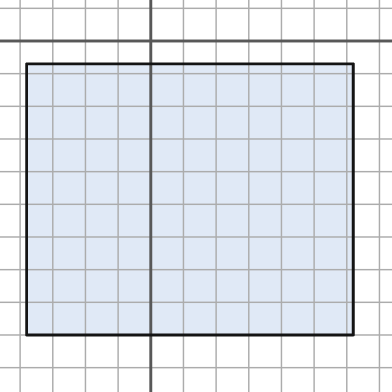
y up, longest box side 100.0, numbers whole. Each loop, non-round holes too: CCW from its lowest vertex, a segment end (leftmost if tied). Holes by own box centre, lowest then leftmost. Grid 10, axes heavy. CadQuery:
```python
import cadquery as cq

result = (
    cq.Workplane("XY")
    .moveTo(-38.0, -90.0)
    .lineTo(62.0, -90.0)
    .lineTo(62.0, -7.0)
    .lineTo(-38.0, -7.0)
    .close()
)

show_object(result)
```